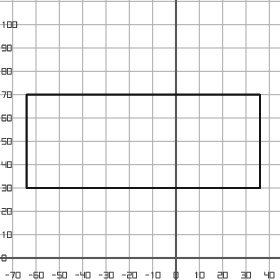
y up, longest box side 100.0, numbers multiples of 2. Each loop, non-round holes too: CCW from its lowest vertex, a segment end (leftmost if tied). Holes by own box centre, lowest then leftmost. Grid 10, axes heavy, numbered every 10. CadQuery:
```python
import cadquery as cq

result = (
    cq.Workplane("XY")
    .moveTo(-64.0, 30.0)
    .lineTo(36.0, 30.0)
    .lineTo(36.0, 70.0)
    .lineTo(-64.0, 70.0)
    .close()
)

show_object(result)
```